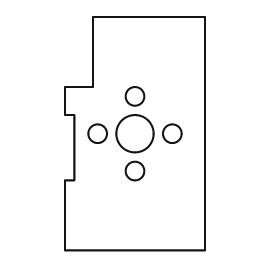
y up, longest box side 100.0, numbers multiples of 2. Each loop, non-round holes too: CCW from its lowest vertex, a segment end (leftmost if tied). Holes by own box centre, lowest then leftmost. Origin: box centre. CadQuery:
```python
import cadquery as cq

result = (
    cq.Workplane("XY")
    .moveTo(-30.0, -50.0)
    .lineTo(30.0, -50.0)
    .lineTo(30.0, 50.0)
    .lineTo(-18.0, 50.0)
    .lineTo(-18.0, 20.0)
    .lineTo(-30.0, 20.0)
    .lineTo(-30.0, 8.0)
    .lineTo(-26.0, 8.0)
    .lineTo(-26.0, -20.0)
    .lineTo(-30.0, -20.0)
    .close()
    .moveTo(0.0, -16.0)
    .circle(4.0)
    .moveTo(-16.0, 0.0)
    .circle(4.0)
    .moveTo(0.0, 0.0)
    .circle(8.0)
    .moveTo(16.0, 0.0)
    .circle(4.0)
    .moveTo(0.0, 16.0)
    .circle(4.0)
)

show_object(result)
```